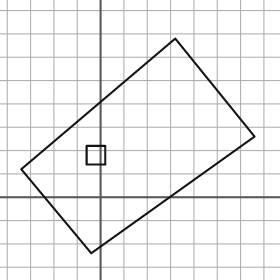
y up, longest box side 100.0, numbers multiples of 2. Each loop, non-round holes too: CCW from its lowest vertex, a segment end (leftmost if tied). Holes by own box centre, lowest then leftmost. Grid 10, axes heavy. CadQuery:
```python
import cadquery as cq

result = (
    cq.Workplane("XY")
    .moveTo(-4.0, -24.0)
    .lineTo(66.0, 26.0)
    .lineTo(32.0, 68.0)
    .lineTo(-34.0, 12.0)
    .close()
    .moveTo(-6.0, 14.0)
    .lineTo(2.0, 14.0)
    .lineTo(2.0, 22.0)
    .lineTo(-6.0, 22.0)
    .close()
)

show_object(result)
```